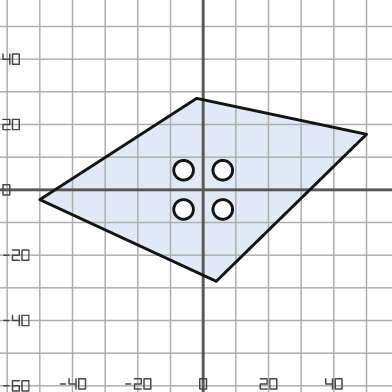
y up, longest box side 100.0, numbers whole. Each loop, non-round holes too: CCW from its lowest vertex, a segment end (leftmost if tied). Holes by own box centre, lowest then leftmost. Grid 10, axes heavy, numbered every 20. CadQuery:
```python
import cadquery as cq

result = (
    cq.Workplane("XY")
    .moveTo(4.0, -28.0)
    .lineTo(50.0, 17.0)
    .lineTo(-2.0, 28.0)
    .lineTo(-50.0, -3.0)
    .close()
    .moveTo(-6.0, -6.0)
    .circle(3.0)
    .moveTo(6.0, -6.0)
    .circle(3.0)
    .moveTo(-6.0, 6.0)
    .circle(3.0)
    .moveTo(6.0, 6.0)
    .circle(3.0)
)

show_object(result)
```